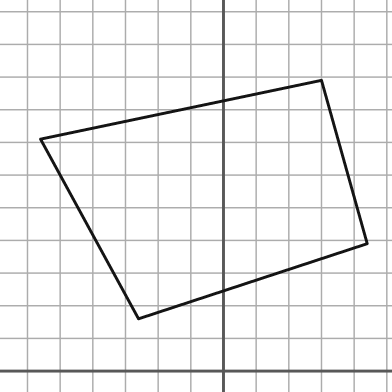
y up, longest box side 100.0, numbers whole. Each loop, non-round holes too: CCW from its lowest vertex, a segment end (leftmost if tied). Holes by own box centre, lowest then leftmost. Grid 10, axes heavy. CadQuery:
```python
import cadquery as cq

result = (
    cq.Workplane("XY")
    .moveTo(-26.0, 16.0)
    .lineTo(44.0, 39.0)
    .lineTo(30.0, 89.0)
    .lineTo(-56.0, 71.0)
    .close()
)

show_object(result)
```